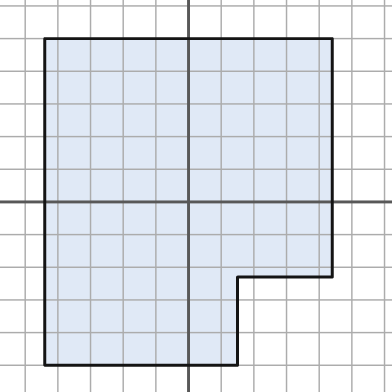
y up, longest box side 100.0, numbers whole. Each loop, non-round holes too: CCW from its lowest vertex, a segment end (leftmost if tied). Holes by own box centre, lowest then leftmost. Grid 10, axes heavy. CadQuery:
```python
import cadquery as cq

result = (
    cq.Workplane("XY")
    .moveTo(-44.0, -50.0)
    .lineTo(15.0, -50.0)
    .lineTo(15.0, -23.0)
    .lineTo(44.0, -23.0)
    .lineTo(44.0, 50.0)
    .lineTo(-44.0, 50.0)
    .close()
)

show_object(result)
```